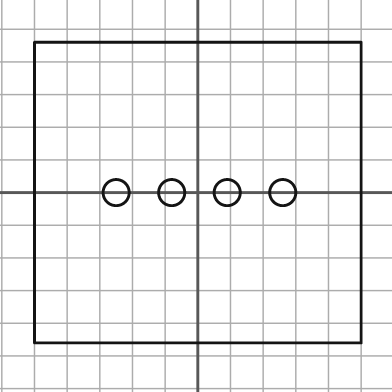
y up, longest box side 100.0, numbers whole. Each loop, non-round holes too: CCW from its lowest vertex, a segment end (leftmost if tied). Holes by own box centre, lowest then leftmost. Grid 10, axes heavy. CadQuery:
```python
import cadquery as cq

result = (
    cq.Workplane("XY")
    .moveTo(-50.0, -46.0)
    .lineTo(50.0, -46.0)
    .lineTo(50.0, 46.0)
    .lineTo(-50.0, 46.0)
    .close()
    .moveTo(-25.0, 0.0)
    .circle(4.0)
    .moveTo(-8.0, 0.0)
    .circle(4.0)
    .moveTo(9.0, 0.0)
    .circle(4.0)
    .moveTo(26.0, 0.0)
    .circle(4.0)
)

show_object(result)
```